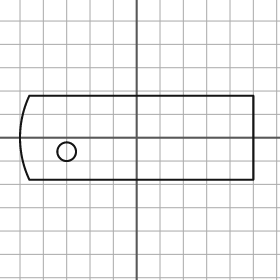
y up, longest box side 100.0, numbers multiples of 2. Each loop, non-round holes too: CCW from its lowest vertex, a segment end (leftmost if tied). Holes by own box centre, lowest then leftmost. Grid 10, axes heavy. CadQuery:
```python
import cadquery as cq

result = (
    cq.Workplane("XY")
    .moveTo(-46.0, -18.0)
    .lineTo(50.0, -18.0)
    .lineTo(50.0, 18.0)
    .lineTo(-46.0, 18.0)
    .threePointArc((-50.0, 0.0), (-46.0, -18.0))
    .close()
    .moveTo(-30.0, -6.0)
    .circle(4.0)
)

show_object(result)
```